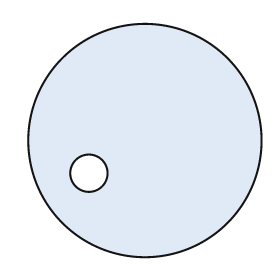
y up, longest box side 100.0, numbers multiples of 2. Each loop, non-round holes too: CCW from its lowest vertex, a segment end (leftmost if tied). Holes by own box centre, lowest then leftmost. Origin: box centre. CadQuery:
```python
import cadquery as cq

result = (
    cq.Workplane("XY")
    .moveTo(0.0, 0.0)
    .circle(50.0)
    .moveTo(-24.0, -14.0)
    .circle(8.0)
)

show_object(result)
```